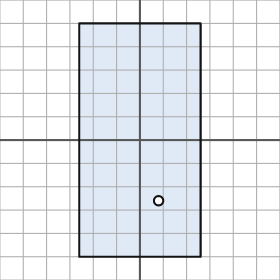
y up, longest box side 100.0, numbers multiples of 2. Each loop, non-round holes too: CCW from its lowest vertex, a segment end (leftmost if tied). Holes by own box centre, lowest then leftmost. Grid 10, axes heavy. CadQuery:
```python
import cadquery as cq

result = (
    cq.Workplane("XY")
    .moveTo(-26.0, -50.0)
    .lineTo(26.0, -50.0)
    .lineTo(26.0, 50.0)
    .lineTo(-26.0, 50.0)
    .close()
    .moveTo(8.0, -26.0)
    .circle(2.0)
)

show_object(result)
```